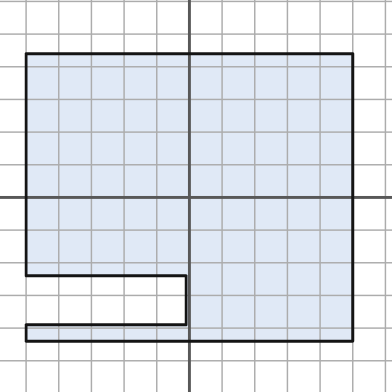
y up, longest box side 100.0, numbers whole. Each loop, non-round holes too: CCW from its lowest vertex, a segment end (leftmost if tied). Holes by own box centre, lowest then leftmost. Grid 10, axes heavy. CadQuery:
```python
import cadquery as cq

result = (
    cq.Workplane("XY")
    .moveTo(-50.0, -44.0)
    .lineTo(50.0, -44.0)
    .lineTo(50.0, 44.0)
    .lineTo(-50.0, 44.0)
    .lineTo(-50.0, -24.0)
    .lineTo(-1.0, -24.0)
    .lineTo(-1.0, -39.0)
    .lineTo(-50.0, -39.0)
    .close()
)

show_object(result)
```